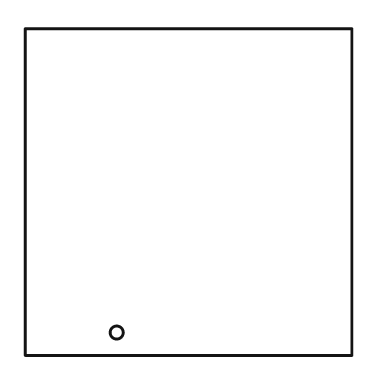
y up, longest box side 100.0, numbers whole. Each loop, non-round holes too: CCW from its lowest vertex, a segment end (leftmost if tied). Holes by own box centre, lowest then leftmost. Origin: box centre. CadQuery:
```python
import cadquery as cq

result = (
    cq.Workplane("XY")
    .moveTo(-50.0, -50.0)
    .lineTo(50.0, -50.0)
    .lineTo(50.0, 50.0)
    .lineTo(-50.0, 50.0)
    .close()
    .moveTo(-22.0, -43.0)
    .circle(2.0)
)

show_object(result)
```